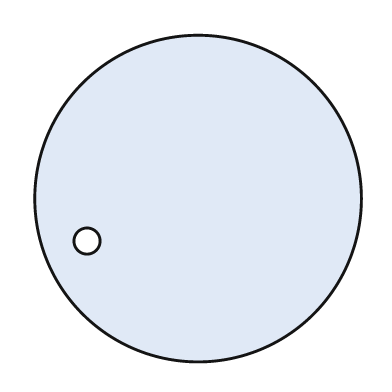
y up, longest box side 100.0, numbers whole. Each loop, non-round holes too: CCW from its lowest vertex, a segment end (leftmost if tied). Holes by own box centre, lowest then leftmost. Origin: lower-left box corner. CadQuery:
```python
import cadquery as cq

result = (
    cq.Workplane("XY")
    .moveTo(50.0, 50.0)
    .circle(50.0)
    .moveTo(16.0, 37.0)
    .circle(4.0)
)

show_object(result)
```